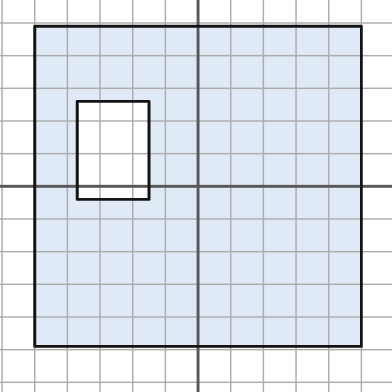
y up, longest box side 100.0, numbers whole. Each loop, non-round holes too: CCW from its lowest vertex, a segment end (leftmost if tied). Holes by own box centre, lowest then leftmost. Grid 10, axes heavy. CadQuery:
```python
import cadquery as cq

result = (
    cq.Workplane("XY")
    .moveTo(-50.0, -49.0)
    .lineTo(50.0, -49.0)
    .lineTo(50.0, 49.0)
    .lineTo(-50.0, 49.0)
    .close()
    .moveTo(-37.0, -4.0)
    .lineTo(-15.0, -4.0)
    .lineTo(-15.0, 26.0)
    .lineTo(-37.0, 26.0)
    .close()
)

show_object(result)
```